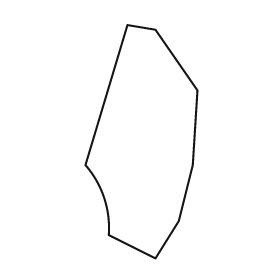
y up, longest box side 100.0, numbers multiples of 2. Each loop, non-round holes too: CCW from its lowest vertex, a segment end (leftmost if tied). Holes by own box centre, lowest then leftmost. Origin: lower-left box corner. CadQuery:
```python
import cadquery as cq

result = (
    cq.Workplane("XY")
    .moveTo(30.0, 0.0)
    .lineTo(40.0, 16.0)
    .lineTo(46.0, 40.0)
    .lineTo(48.0, 72.0)
    .lineTo(30.0, 98.0)
    .lineTo(18.0, 100.0)
    .lineTo(0.0, 40.0)
    .threePointArc((8.0, 26.0), (10.0, 10.0))
    .close()
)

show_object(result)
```